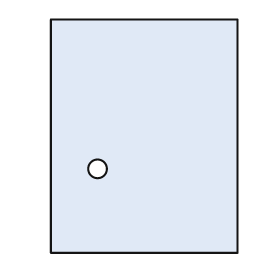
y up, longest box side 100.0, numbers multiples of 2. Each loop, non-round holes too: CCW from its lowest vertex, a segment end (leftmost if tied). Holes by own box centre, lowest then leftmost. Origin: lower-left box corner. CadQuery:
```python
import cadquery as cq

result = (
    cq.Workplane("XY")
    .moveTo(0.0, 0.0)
    .lineTo(80.0, 0.0)
    .lineTo(80.0, 100.0)
    .lineTo(0.0, 100.0)
    .close()
    .moveTo(20.0, 36.0)
    .circle(4.0)
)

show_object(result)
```